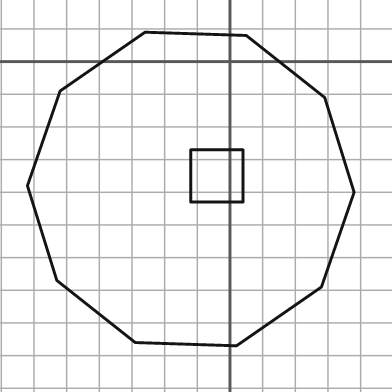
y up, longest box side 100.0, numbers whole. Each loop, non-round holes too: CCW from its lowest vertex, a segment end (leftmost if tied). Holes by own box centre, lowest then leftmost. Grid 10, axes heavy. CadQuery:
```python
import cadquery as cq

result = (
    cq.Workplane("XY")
    .moveTo(2.0, -87.0)
    .lineTo(28.0, -69.0)
    .lineTo(38.0, -40.0)
    .lineTo(29.0, -11.0)
    .lineTo(5.0, 8.0)
    .lineTo(-26.0, 9.0)
    .lineTo(-52.0, -9.0)
    .lineTo(-62.0, -38.0)
    .lineTo(-53.0, -67.0)
    .lineTo(-29.0, -86.0)
    .close()
    .moveTo(-12.0, -43.0)
    .lineTo(4.0, -43.0)
    .lineTo(4.0, -27.0)
    .lineTo(-12.0, -27.0)
    .close()
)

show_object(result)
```